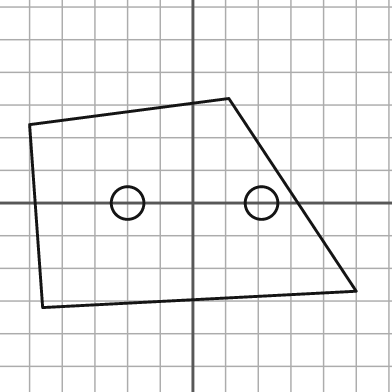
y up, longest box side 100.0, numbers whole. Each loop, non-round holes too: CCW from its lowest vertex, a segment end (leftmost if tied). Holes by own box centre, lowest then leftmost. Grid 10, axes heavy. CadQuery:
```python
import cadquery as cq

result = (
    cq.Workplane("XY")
    .moveTo(-46.0, -32.0)
    .lineTo(50.0, -27.0)
    .lineTo(11.0, 32.0)
    .lineTo(-50.0, 24.0)
    .close()
    .moveTo(-20.0, 0.0)
    .circle(5.0)
    .moveTo(21.0, 0.0)
    .circle(5.0)
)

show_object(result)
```